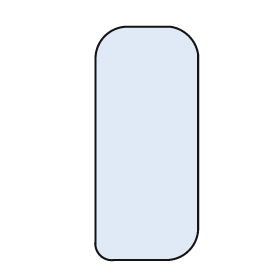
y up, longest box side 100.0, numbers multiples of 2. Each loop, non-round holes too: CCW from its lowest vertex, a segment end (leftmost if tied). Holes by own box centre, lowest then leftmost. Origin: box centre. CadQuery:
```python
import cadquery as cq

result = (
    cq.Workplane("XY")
    .moveTo(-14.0, -50.0)
    .lineTo(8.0, -50.0)
    .threePointArc((18.0, -46.0), (22.0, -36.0))
    .lineTo(22.0, 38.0)
    .threePointArc((18.0, 46.0), (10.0, 50.0))
    .lineTo(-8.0, 50.0)
    .threePointArc((-18.0, 46.0), (-22.0, 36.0))
    .lineTo(-22.0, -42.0)
    .threePointArc((-20.0, -48.0), (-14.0, -50.0))
    .close()
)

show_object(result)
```